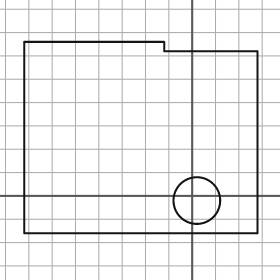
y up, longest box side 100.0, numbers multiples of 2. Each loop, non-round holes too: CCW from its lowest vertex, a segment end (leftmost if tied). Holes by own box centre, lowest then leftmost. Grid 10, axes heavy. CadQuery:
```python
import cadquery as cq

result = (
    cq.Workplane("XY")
    .moveTo(-72.0, -16.0)
    .lineTo(28.0, -16.0)
    .lineTo(28.0, 62.0)
    .lineTo(-12.0, 62.0)
    .lineTo(-12.0, 66.0)
    .lineTo(-72.0, 66.0)
    .close()
    .moveTo(2.0, -2.0)
    .circle(10.0)
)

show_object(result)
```